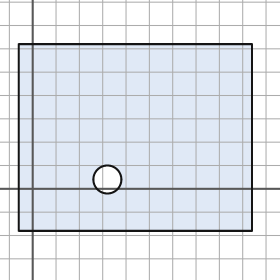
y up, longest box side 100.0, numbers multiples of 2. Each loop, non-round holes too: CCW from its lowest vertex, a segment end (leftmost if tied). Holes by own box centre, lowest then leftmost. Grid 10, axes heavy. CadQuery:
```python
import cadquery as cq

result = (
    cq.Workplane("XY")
    .moveTo(-6.0, -18.0)
    .lineTo(94.0, -18.0)
    .lineTo(94.0, 62.0)
    .lineTo(-6.0, 62.0)
    .close()
    .moveTo(32.0, 4.0)
    .circle(6.0)
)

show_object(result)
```